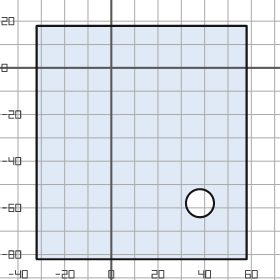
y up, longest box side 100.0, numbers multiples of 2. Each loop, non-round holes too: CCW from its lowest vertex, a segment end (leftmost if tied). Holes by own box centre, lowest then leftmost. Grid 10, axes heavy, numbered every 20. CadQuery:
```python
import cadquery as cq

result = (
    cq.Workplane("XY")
    .moveTo(-32.0, -82.0)
    .lineTo(58.0, -82.0)
    .lineTo(58.0, 18.0)
    .lineTo(-32.0, 18.0)
    .close()
    .moveTo(38.0, -58.0)
    .circle(6.0)
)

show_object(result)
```